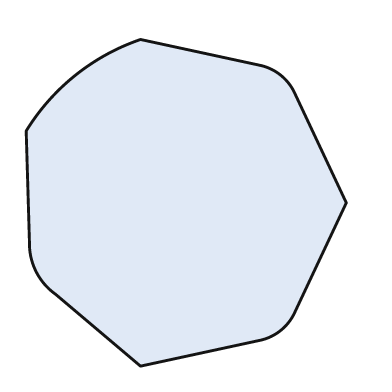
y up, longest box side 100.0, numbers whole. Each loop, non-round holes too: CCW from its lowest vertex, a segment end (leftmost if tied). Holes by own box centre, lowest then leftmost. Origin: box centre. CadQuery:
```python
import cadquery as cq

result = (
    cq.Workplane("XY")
    .moveTo(-14.0, -50.0)
    .lineTo(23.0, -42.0)
    .threePointArc((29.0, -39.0), (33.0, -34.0))
    .lineTo(49.0, 0.0)
    .lineTo(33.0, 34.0)
    .threePointArc((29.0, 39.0), (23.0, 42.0))
    .lineTo(-14.0, 50.0)
    .threePointArc((-34.0, 39.0), (-49.0, 22.0))
    .lineTo(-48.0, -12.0)
    .threePointArc((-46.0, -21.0), (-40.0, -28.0))
    .close()
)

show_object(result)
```